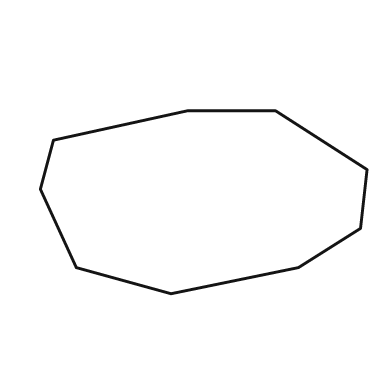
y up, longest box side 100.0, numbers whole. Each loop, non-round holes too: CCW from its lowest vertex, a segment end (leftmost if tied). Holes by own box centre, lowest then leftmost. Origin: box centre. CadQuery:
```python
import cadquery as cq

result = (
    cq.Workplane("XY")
    .moveTo(-10.0, -28.0)
    .lineTo(29.0, -20.0)
    .lineTo(48.0, -8.0)
    .lineTo(50.0, 10.0)
    .lineTo(22.0, 28.0)
    .lineTo(-5.0, 28.0)
    .lineTo(-46.0, 19.0)
    .lineTo(-50.0, 4.0)
    .lineTo(-39.0, -20.0)
    .close()
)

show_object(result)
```